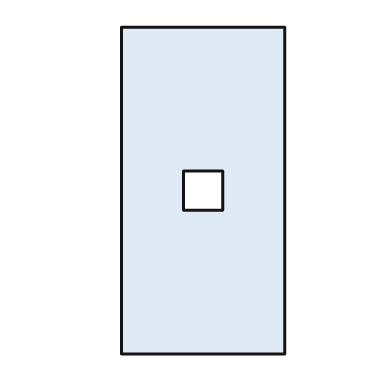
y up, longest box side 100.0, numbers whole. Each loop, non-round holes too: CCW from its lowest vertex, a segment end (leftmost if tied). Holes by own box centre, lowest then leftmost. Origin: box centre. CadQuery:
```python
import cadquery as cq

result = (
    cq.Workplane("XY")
    .moveTo(-25.0, -50.0)
    .lineTo(25.0, -50.0)
    .lineTo(25.0, 50.0)
    .lineTo(-25.0, 50.0)
    .close()
    .moveTo(-6.0, -6.0)
    .lineTo(6.0, -6.0)
    .lineTo(6.0, 6.0)
    .lineTo(-6.0, 6.0)
    .close()
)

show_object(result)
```